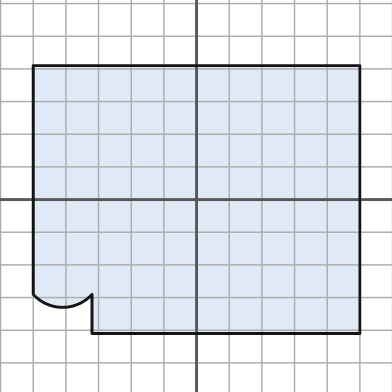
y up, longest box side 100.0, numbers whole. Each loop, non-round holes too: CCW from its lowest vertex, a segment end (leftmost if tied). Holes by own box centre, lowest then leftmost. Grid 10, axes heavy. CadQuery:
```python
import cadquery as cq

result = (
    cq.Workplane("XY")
    .moveTo(-32.0, -41.0)
    .lineTo(50.0, -41.0)
    .lineTo(50.0, 41.0)
    .lineTo(-50.0, 41.0)
    .lineTo(-50.0, -29.0)
    .threePointArc((-41.0, -33.0), (-32.0, -29.0))
    .close()
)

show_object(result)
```